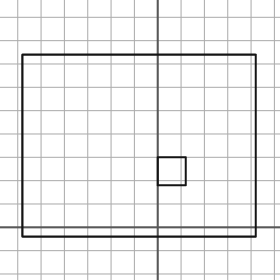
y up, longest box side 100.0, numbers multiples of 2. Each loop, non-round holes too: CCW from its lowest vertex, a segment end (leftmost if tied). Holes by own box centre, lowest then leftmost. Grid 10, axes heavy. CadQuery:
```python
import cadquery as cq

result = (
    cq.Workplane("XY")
    .moveTo(-58.0, -4.0)
    .lineTo(42.0, -4.0)
    .lineTo(42.0, 74.0)
    .lineTo(-58.0, 74.0)
    .close()
    .moveTo(0.0, 18.0)
    .lineTo(12.0, 18.0)
    .lineTo(12.0, 30.0)
    .lineTo(0.0, 30.0)
    .close()
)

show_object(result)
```